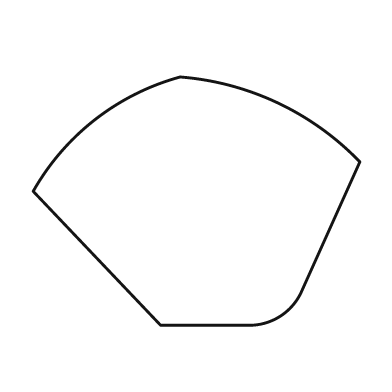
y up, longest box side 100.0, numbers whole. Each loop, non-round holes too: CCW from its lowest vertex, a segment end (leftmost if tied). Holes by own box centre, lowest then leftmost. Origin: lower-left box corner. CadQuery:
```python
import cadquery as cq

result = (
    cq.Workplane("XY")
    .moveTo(39.0, 0.0)
    .lineTo(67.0, 0.0)
    .threePointArc((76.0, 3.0), (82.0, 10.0))
    .lineTo(100.0, 50.0)
    .threePointArc((75.0, 68.0), (45.0, 76.0))
    .threePointArc((19.0, 63.0), (0.0, 41.0))
    .close()
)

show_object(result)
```